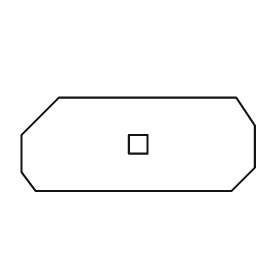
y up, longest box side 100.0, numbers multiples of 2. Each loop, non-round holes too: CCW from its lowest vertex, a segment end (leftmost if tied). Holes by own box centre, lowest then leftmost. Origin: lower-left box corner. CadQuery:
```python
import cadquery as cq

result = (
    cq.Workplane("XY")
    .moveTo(6.0, 0.0)
    .lineTo(90.0, 0.0)
    .lineTo(100.0, 10.0)
    .lineTo(100.0, 28.0)
    .lineTo(92.0, 40.0)
    .lineTo(16.0, 40.0)
    .lineTo(0.0, 24.0)
    .lineTo(0.0, 8.0)
    .close()
    .moveTo(46.0, 16.0)
    .lineTo(54.0, 16.0)
    .lineTo(54.0, 24.0)
    .lineTo(46.0, 24.0)
    .close()
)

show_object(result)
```